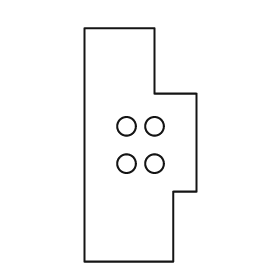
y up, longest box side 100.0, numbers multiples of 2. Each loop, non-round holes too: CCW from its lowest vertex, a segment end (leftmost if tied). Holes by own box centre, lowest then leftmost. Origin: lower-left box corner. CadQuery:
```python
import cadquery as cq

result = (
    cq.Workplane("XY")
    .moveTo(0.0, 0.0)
    .lineTo(38.0, 0.0)
    .lineTo(38.0, 30.0)
    .lineTo(48.0, 30.0)
    .lineTo(48.0, 72.0)
    .lineTo(30.0, 72.0)
    .lineTo(30.0, 100.0)
    .lineTo(0.0, 100.0)
    .close()
    .moveTo(18.0, 42.0)
    .circle(4.0)
    .moveTo(30.0, 42.0)
    .circle(4.0)
    .moveTo(18.0, 58.0)
    .circle(4.0)
    .moveTo(30.0, 58.0)
    .circle(4.0)
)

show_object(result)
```